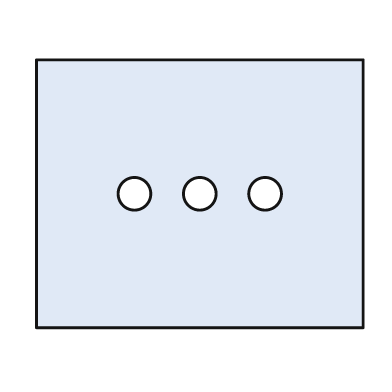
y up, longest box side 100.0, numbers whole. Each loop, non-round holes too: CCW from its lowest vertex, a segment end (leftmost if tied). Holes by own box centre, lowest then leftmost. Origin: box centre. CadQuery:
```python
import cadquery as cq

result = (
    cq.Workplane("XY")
    .moveTo(-50.0, -41.0)
    .lineTo(50.0, -41.0)
    .lineTo(50.0, 41.0)
    .lineTo(-50.0, 41.0)
    .close()
    .moveTo(-20.0, 0.0)
    .circle(5.0)
    .moveTo(0.0, 0.0)
    .circle(5.0)
    .moveTo(20.0, 0.0)
    .circle(5.0)
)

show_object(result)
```